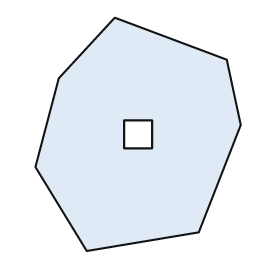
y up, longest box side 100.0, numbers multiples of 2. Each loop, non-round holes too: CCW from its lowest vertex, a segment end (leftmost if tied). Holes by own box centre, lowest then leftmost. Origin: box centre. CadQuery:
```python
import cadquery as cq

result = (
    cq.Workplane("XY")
    .moveTo(-22.0, -50.0)
    .lineTo(26.0, -42.0)
    .lineTo(44.0, 4.0)
    .lineTo(38.0, 32.0)
    .lineTo(-10.0, 50.0)
    .lineTo(-34.0, 24.0)
    .lineTo(-44.0, -14.0)
    .close()
    .moveTo(-6.0, -6.0)
    .lineTo(6.0, -6.0)
    .lineTo(6.0, 6.0)
    .lineTo(-6.0, 6.0)
    .close()
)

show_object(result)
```